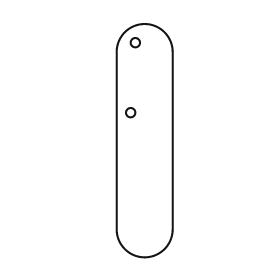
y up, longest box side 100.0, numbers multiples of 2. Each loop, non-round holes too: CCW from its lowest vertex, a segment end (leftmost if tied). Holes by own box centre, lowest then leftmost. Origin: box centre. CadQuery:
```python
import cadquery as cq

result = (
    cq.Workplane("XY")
    .moveTo(-12.0, -38.0)
    .threePointArc((0.0, -50.0), (12.0, -38.0))
    .lineTo(12.0, 38.0)
    .threePointArc((0.0, 50.0), (-12.0, 38.0))
    .close()
    .moveTo(-6.0, 12.0)
    .circle(2.0)
    .moveTo(-4.0, 42.0)
    .circle(2.0)
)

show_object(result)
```